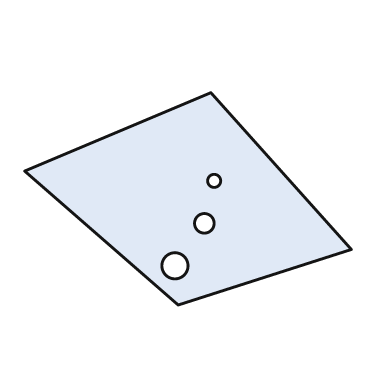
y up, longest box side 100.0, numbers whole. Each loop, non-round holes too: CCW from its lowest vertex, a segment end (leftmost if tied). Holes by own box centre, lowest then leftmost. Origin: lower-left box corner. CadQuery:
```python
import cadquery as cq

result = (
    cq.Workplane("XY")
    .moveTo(47.0, 0.0)
    .lineTo(100.0, 17.0)
    .lineTo(57.0, 65.0)
    .lineTo(0.0, 41.0)
    .close()
    .moveTo(46.0, 12.0)
    .circle(4.0)
    .moveTo(55.0, 25.0)
    .circle(3.0)
    .moveTo(58.0, 38.0)
    .circle(2.0)
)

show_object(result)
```